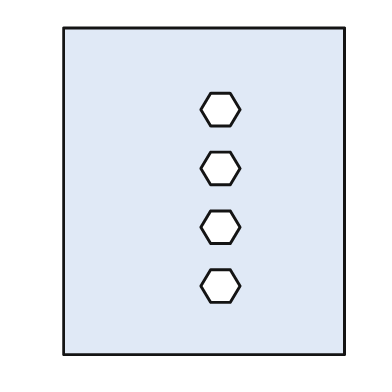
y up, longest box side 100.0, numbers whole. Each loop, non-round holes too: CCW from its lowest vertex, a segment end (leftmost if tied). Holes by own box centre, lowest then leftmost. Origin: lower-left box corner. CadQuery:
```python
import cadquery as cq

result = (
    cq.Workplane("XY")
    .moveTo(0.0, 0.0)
    .lineTo(86.0, 0.0)
    .lineTo(86.0, 100.0)
    .lineTo(0.0, 100.0)
    .close()
    .moveTo(45.0, 16.0)
    .lineTo(51.0, 16.0)
    .lineTo(54.0, 21.0)
    .lineTo(51.0, 26.0)
    .lineTo(45.0, 26.0)
    .lineTo(42.0, 21.0)
    .close()
    .moveTo(45.0, 34.0)
    .lineTo(51.0, 34.0)
    .lineTo(54.0, 39.0)
    .lineTo(51.0, 44.0)
    .lineTo(45.0, 44.0)
    .lineTo(42.0, 39.0)
    .close()
    .moveTo(45.0, 52.0)
    .lineTo(51.0, 52.0)
    .lineTo(54.0, 57.0)
    .lineTo(51.0, 62.0)
    .lineTo(45.0, 62.0)
    .lineTo(42.0, 57.0)
    .close()
    .moveTo(45.0, 70.0)
    .lineTo(51.0, 70.0)
    .lineTo(54.0, 75.0)
    .lineTo(51.0, 80.0)
    .lineTo(45.0, 80.0)
    .lineTo(42.0, 75.0)
    .close()
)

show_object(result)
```